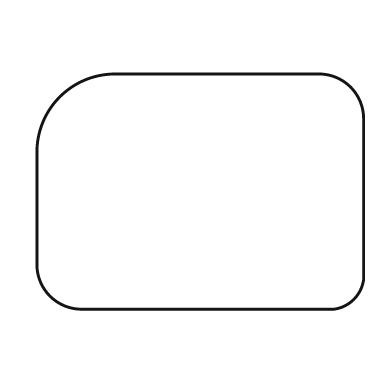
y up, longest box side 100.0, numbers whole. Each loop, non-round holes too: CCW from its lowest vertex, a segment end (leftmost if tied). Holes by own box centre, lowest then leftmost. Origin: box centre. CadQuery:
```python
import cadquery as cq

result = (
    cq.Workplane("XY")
    .moveTo(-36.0, -36.0)
    .lineTo(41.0, -36.0)
    .threePointArc((47.0, -33.0), (50.0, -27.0))
    .lineTo(50.0, 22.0)
    .threePointArc((46.0, 32.0), (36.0, 36.0))
    .lineTo(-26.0, 36.0)
    .threePointArc((-43.0, 29.0), (-50.0, 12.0))
    .lineTo(-50.0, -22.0)
    .threePointArc((-46.0, -32.0), (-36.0, -36.0))
    .close()
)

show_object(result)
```